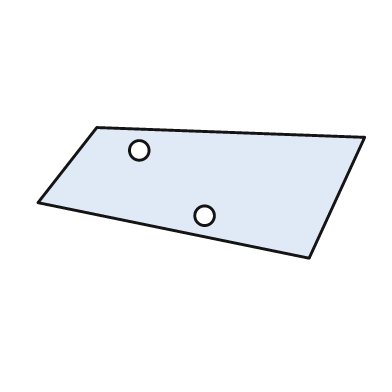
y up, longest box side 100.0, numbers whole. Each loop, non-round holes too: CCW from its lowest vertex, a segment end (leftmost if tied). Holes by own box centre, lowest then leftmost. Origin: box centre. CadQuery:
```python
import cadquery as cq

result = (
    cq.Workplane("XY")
    .moveTo(33.0, -20.0)
    .lineTo(50.0, 17.0)
    .lineTo(-32.0, 20.0)
    .lineTo(-50.0, -3.0)
    .close()
    .moveTo(1.0, -7.0)
    .circle(3.0)
    .moveTo(-19.0, 13.0)
    .circle(3.0)
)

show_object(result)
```